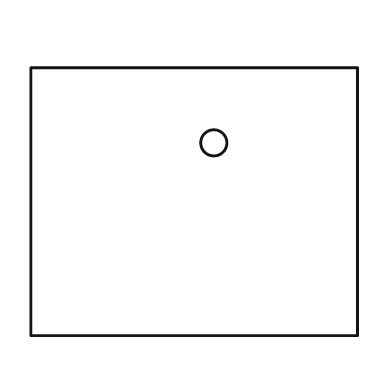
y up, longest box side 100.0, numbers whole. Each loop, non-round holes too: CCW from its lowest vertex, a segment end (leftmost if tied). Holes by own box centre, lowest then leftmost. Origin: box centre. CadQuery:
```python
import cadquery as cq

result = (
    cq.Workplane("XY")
    .moveTo(-50.0, -41.0)
    .lineTo(50.0, -41.0)
    .lineTo(50.0, 41.0)
    .lineTo(-50.0, 41.0)
    .close()
    .moveTo(6.0, 18.0)
    .circle(4.0)
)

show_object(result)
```